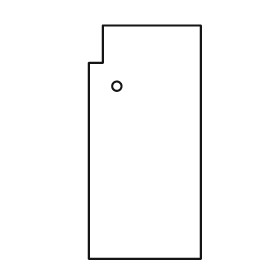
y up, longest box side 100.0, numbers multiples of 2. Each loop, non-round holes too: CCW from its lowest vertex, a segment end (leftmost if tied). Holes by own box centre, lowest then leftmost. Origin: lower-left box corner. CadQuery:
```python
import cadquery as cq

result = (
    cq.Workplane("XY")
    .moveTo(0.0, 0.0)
    .lineTo(48.0, 0.0)
    .lineTo(48.0, 100.0)
    .lineTo(6.0, 100.0)
    .lineTo(6.0, 84.0)
    .lineTo(0.0, 84.0)
    .close()
    .moveTo(12.0, 74.0)
    .circle(2.0)
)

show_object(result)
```